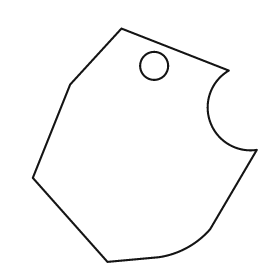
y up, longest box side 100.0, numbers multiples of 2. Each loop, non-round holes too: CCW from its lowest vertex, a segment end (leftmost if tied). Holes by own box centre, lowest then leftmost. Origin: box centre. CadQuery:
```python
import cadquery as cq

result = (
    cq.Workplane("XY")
    .moveTo(-16.0, -50.0)
    .lineTo(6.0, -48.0)
    .threePointArc((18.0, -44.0), (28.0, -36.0))
    .lineTo(48.0, -2.0)
    .threePointArc((28.0, 10.0), (36.0, 32.0))
    .lineTo(-10.0, 50.0)
    .lineTo(-32.0, 26.0)
    .lineTo(-48.0, -14.0)
    .close()
    .moveTo(4.0, 34.0)
    .circle(6.0)
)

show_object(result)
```